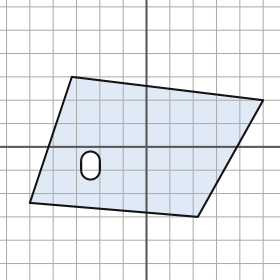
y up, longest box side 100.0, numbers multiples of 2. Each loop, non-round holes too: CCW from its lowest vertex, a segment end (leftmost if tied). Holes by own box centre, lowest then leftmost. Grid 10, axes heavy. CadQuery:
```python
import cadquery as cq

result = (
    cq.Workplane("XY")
    .moveTo(22.0, -30.0)
    .lineTo(50.0, 20.0)
    .lineTo(-32.0, 30.0)
    .lineTo(-50.0, -24.0)
    .close()
    .moveTo(-28.0, -10.0)
    .threePointArc((-24.0, -14.0), (-20.0, -10.0))
    .lineTo(-20.0, -6.0)
    .threePointArc((-24.0, -2.0), (-28.0, -6.0))
    .close()
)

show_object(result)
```